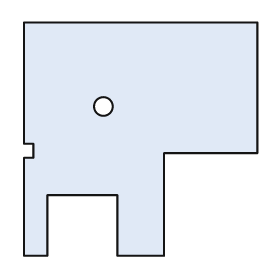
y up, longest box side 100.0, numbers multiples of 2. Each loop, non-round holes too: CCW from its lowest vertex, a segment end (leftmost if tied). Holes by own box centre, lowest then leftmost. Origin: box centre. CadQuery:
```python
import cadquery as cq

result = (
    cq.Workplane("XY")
    .moveTo(-50.0, -50.0)
    .lineTo(-40.0, -50.0)
    .lineTo(-40.0, -24.0)
    .lineTo(-10.0, -24.0)
    .lineTo(-10.0, -50.0)
    .lineTo(10.0, -50.0)
    .lineTo(10.0, -6.0)
    .lineTo(50.0, -6.0)
    .lineTo(50.0, 50.0)
    .lineTo(-50.0, 50.0)
    .lineTo(-50.0, -2.0)
    .lineTo(-46.0, -2.0)
    .lineTo(-46.0, -8.0)
    .lineTo(-50.0, -8.0)
    .close()
    .moveTo(-16.0, 14.0)
    .circle(4.0)
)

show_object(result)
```